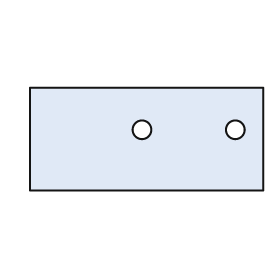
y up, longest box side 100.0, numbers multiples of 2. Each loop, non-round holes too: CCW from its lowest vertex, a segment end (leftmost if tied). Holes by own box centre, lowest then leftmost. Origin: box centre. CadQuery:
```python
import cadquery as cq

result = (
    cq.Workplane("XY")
    .moveTo(-50.0, -22.0)
    .lineTo(50.0, -22.0)
    .lineTo(50.0, 22.0)
    .lineTo(-50.0, 22.0)
    .close()
    .moveTo(-2.0, 4.0)
    .circle(4.0)
    .moveTo(38.0, 4.0)
    .circle(4.0)
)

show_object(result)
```